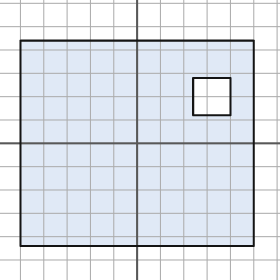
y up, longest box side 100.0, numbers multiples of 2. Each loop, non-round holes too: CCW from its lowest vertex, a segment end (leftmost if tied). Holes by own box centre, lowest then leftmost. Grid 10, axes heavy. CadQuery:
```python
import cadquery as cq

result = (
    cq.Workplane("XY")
    .moveTo(-50.0, -44.0)
    .lineTo(50.0, -44.0)
    .lineTo(50.0, 44.0)
    .lineTo(-50.0, 44.0)
    .close()
    .moveTo(24.0, 12.0)
    .lineTo(40.0, 12.0)
    .lineTo(40.0, 28.0)
    .lineTo(24.0, 28.0)
    .close()
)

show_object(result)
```